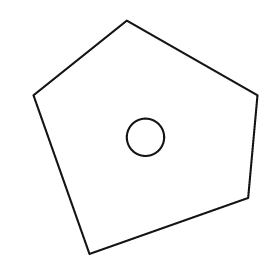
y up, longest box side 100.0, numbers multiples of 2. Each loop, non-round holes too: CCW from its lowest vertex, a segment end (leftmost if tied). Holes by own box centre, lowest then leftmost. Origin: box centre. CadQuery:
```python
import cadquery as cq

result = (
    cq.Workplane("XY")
    .moveTo(-24.0, -50.0)
    .lineTo(44.0, -26.0)
    .lineTo(48.0, 18.0)
    .lineTo(-8.0, 50.0)
    .lineTo(-48.0, 18.0)
    .close()
    .moveTo(0.0, 0.0)
    .circle(8.0)
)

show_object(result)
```